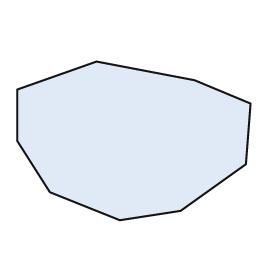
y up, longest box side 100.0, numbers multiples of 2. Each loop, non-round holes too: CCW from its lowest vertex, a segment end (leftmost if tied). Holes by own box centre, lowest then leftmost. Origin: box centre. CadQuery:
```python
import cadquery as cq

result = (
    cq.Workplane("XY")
    .moveTo(-6.0, -34.0)
    .lineTo(20.0, -30.0)
    .lineTo(48.0, -10.0)
    .lineTo(50.0, 16.0)
    .lineTo(26.0, 26.0)
    .lineTo(-16.0, 34.0)
    .lineTo(-50.0, 22.0)
    .lineTo(-50.0, 0.0)
    .lineTo(-36.0, -22.0)
    .close()
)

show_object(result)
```